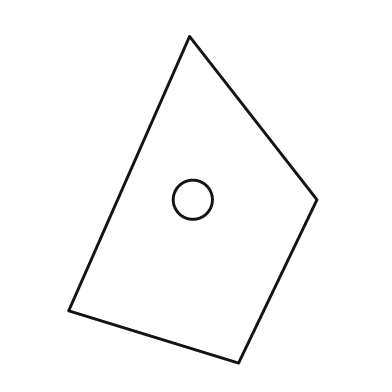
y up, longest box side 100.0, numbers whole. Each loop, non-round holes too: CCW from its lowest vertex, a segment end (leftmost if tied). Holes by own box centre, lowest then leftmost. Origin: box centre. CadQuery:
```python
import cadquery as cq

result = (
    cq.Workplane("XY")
    .moveTo(14.0, -50.0)
    .lineTo(38.0, 0.0)
    .lineTo(-1.0, 50.0)
    .lineTo(-38.0, -34.0)
    .close()
    .moveTo(0.0, 0.0)
    .circle(6.0)
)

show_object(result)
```